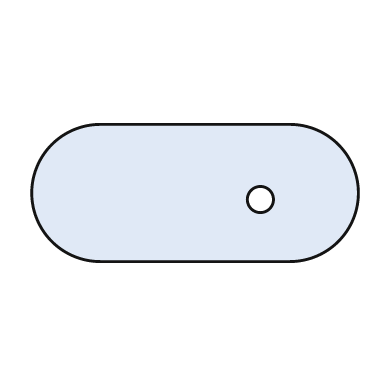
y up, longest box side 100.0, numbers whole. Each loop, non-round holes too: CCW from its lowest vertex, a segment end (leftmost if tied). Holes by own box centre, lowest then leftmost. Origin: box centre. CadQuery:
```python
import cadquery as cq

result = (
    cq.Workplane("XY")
    .moveTo(-29.0, -21.0)
    .lineTo(29.0, -21.0)
    .threePointArc((50.0, 0.0), (29.0, 21.0))
    .lineTo(-29.0, 21.0)
    .threePointArc((-50.0, 0.0), (-29.0, -21.0))
    .close()
    .moveTo(20.0, -2.0)
    .circle(4.0)
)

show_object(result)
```